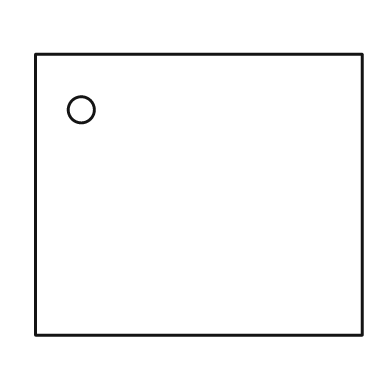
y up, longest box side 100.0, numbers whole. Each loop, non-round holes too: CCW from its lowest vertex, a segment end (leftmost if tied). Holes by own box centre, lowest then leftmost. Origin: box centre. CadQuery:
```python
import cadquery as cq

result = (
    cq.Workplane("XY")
    .moveTo(-50.0, -43.0)
    .lineTo(50.0, -43.0)
    .lineTo(50.0, 43.0)
    .lineTo(-50.0, 43.0)
    .close()
    .moveTo(-36.0, 26.0)
    .circle(4.0)
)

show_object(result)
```